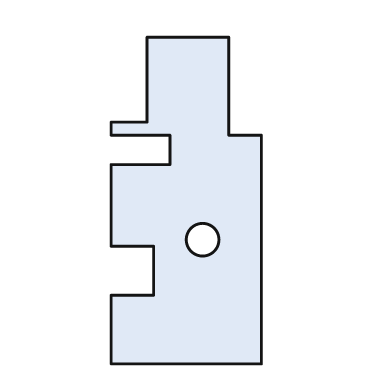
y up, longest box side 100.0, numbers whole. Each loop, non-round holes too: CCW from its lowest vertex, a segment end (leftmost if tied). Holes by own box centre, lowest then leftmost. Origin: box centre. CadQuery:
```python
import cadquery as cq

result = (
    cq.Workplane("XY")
    .moveTo(-23.0, -50.0)
    .lineTo(23.0, -50.0)
    .lineTo(23.0, 20.0)
    .lineTo(13.0, 20.0)
    .lineTo(13.0, 50.0)
    .lineTo(-12.0, 50.0)
    .lineTo(-12.0, 24.0)
    .lineTo(-23.0, 24.0)
    .lineTo(-23.0, 20.0)
    .lineTo(-5.0, 20.0)
    .lineTo(-5.0, 11.0)
    .lineTo(-23.0, 11.0)
    .lineTo(-23.0, -14.0)
    .lineTo(-10.0, -14.0)
    .lineTo(-10.0, -29.0)
    .lineTo(-23.0, -29.0)
    .close()
    .moveTo(5.0, -12.0)
    .circle(5.0)
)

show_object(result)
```